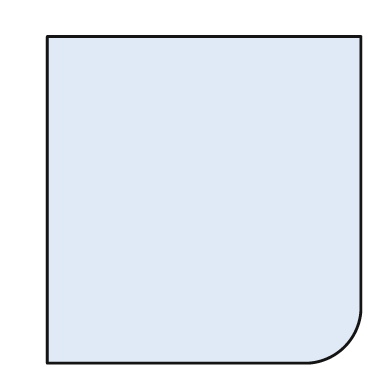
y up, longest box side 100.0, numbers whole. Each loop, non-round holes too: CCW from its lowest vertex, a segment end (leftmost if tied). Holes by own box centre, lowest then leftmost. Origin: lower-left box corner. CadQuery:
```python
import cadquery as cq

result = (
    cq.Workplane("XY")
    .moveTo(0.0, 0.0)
    .lineTo(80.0, 0.0)
    .threePointArc((91.0, 5.0), (96.0, 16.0))
    .lineTo(96.0, 100.0)
    .lineTo(0.0, 100.0)
    .close()
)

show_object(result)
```